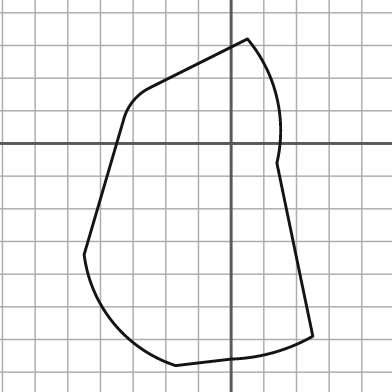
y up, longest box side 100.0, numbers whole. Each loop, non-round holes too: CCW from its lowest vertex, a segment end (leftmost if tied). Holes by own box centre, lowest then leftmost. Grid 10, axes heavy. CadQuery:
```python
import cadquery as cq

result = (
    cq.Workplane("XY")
    .moveTo(-17.0, -68.0)
    .lineTo(0.0, -66.0)
    .threePointArc((13.0, -64.0), (25.0, -59.0))
    .lineTo(14.0, -6.0)
    .threePointArc((14.0, 14.0), (5.0, 32.0))
    .lineTo(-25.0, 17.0)
    .threePointArc((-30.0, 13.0), (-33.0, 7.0))
    .lineTo(-45.0, -34.0)
    .threePointArc((-36.0, -55.0), (-17.0, -68.0))
    .close()
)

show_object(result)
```